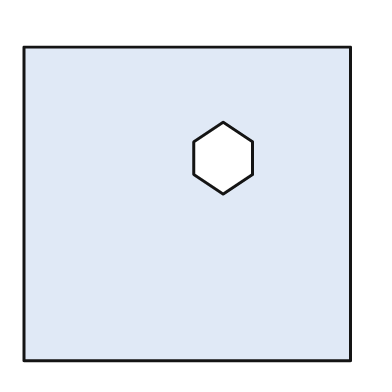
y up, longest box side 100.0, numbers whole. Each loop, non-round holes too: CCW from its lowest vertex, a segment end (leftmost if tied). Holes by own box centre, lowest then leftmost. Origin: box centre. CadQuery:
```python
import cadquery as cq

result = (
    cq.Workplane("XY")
    .moveTo(-50.0, -48.0)
    .lineTo(50.0, -48.0)
    .lineTo(50.0, 48.0)
    .lineTo(-50.0, 48.0)
    .close()
    .moveTo(11.0, 3.0)
    .lineTo(20.0, 9.0)
    .lineTo(20.0, 19.0)
    .lineTo(11.0, 25.0)
    .lineTo(2.0, 19.0)
    .lineTo(2.0, 9.0)
    .close()
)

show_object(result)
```